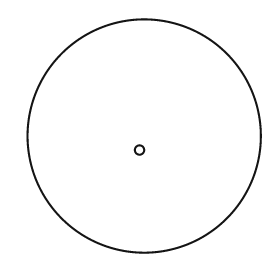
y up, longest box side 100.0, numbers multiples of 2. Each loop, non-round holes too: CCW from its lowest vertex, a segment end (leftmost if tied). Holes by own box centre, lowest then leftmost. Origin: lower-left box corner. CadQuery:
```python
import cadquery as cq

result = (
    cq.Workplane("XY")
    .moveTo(50.0, 50.0)
    .circle(50.0)
    .moveTo(48.0, 44.0)
    .circle(2.0)
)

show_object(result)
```